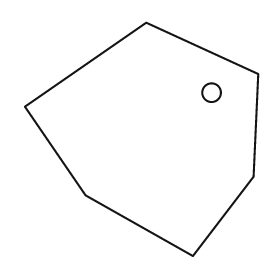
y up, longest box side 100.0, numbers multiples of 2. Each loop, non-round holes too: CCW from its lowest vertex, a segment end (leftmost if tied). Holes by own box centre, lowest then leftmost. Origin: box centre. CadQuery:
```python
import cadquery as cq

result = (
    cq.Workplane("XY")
    .moveTo(22.0, -50.0)
    .lineTo(48.0, -16.0)
    .lineTo(50.0, 28.0)
    .lineTo(2.0, 50.0)
    .lineTo(-50.0, 14.0)
    .lineTo(-24.0, -24.0)
    .close()
    .moveTo(30.0, 20.0)
    .circle(4.0)
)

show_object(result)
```